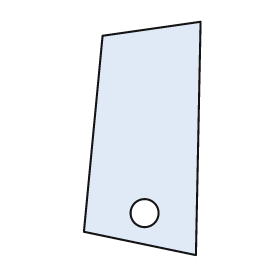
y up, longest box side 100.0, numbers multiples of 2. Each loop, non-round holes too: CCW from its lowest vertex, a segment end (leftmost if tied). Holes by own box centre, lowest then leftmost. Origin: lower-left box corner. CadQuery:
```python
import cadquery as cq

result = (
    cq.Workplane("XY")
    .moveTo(48.0, 0.0)
    .lineTo(50.0, 100.0)
    .lineTo(8.0, 94.0)
    .lineTo(0.0, 10.0)
    .close()
    .moveTo(26.0, 18.0)
    .circle(6.0)
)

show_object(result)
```